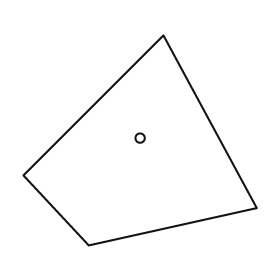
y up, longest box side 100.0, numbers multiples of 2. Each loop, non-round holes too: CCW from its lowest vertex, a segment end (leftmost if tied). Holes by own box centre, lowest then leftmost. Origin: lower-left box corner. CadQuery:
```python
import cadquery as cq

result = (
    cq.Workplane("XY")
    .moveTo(28.0, 0.0)
    .lineTo(100.0, 16.0)
    .lineTo(60.0, 90.0)
    .lineTo(0.0, 30.0)
    .close()
    .moveTo(50.0, 46.0)
    .circle(2.0)
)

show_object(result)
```